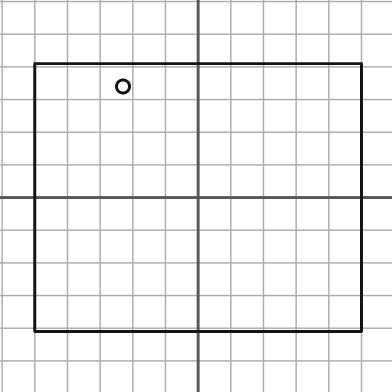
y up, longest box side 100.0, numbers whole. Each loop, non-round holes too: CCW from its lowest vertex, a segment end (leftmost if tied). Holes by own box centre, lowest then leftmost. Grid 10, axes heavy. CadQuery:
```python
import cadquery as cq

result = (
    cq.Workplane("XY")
    .moveTo(-50.0, -41.0)
    .lineTo(50.0, -41.0)
    .lineTo(50.0, 41.0)
    .lineTo(-50.0, 41.0)
    .close()
    .moveTo(-23.0, 34.0)
    .circle(2.0)
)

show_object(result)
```